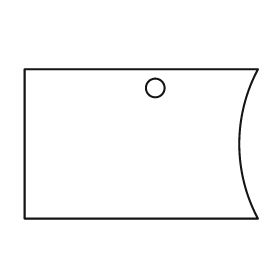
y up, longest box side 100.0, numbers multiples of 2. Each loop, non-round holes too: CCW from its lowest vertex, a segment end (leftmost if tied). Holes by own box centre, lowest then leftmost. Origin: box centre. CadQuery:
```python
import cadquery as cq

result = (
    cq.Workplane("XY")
    .moveTo(-50.0, -32.0)
    .lineTo(50.0, -32.0)
    .threePointArc((42.0, 0.0), (50.0, 32.0))
    .lineTo(-50.0, 32.0)
    .close()
    .moveTo(6.0, 24.0)
    .circle(4.0)
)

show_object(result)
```